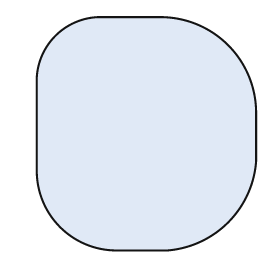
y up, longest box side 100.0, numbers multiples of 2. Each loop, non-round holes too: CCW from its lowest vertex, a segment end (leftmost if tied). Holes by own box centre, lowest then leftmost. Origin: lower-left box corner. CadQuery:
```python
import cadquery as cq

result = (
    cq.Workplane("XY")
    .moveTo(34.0, 0.0)
    .lineTo(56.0, 0.0)
    .threePointArc((82.0, 12.0), (94.0, 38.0))
    .lineTo(94.0, 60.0)
    .threePointArc((82.0, 88.0), (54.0, 100.0))
    .lineTo(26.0, 100.0)
    .threePointArc((8.0, 92.0), (0.0, 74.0))
    .lineTo(0.0, 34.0)
    .threePointArc((10.0, 10.0), (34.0, 0.0))
    .close()
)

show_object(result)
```